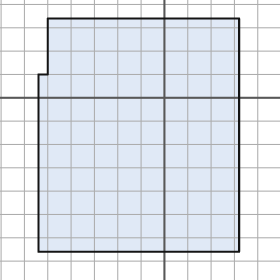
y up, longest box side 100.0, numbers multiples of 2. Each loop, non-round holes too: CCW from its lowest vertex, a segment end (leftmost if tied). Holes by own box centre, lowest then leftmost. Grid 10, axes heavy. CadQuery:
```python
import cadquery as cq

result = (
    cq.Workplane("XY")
    .moveTo(-54.0, -66.0)
    .lineTo(32.0, -66.0)
    .lineTo(32.0, 34.0)
    .lineTo(-50.0, 34.0)
    .lineTo(-50.0, 10.0)
    .lineTo(-54.0, 10.0)
    .close()
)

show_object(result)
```